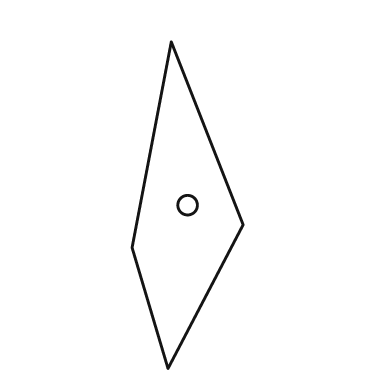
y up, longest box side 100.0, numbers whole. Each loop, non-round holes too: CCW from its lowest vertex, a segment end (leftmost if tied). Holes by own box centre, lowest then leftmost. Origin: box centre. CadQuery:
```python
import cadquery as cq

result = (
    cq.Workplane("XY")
    .moveTo(-6.0, -50.0)
    .lineTo(17.0, -6.0)
    .lineTo(-5.0, 50.0)
    .lineTo(-17.0, -13.0)
    .close()
    .moveTo(0.0, 0.0)
    .circle(3.0)
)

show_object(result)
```